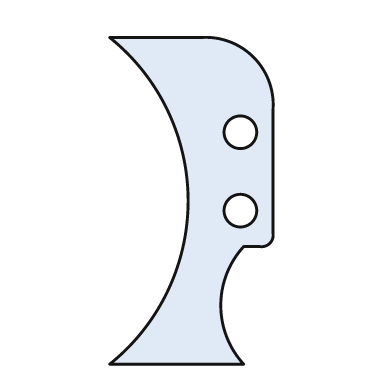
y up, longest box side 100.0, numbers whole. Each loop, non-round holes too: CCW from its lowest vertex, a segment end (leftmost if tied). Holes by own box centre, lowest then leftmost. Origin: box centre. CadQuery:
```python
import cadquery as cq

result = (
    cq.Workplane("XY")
    .moveTo(-25.0, -50.0)
    .lineTo(16.0, -50.0)
    .threePointArc((9.0, -32.0), (16.0, -14.0))
    .lineTo(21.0, -14.0)
    .threePointArc((24.0, -13.0), (25.0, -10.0))
    .lineTo(25.0, 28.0)
    .threePointArc((19.0, 44.0), (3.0, 50.0))
    .lineTo(-25.0, 50.0)
    .threePointArc((-1.0, 0.0), (-25.0, -50.0))
    .close()
    .moveTo(15.0, -3.0)
    .circle(5.0)
    .moveTo(15.0, 21.0)
    .circle(5.0)
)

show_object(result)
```